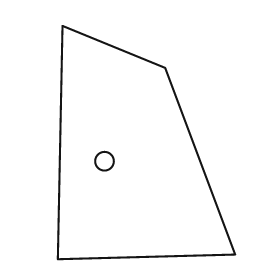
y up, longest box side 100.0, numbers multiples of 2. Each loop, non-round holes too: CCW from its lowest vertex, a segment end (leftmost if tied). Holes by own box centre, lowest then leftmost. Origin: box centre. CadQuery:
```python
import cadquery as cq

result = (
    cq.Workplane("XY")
    .moveTo(-38.0, -50.0)
    .lineTo(38.0, -48.0)
    .lineTo(8.0, 32.0)
    .lineTo(-36.0, 50.0)
    .close()
    .moveTo(-18.0, -8.0)
    .circle(4.0)
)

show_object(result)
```